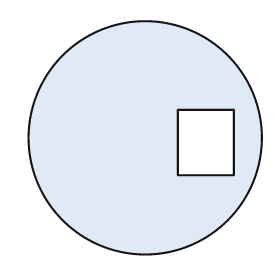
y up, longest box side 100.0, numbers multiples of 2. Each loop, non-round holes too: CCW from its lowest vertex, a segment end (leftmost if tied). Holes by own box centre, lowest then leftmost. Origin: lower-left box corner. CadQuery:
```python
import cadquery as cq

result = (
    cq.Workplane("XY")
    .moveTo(50.0, 50.0)
    .circle(50.0)
    .moveTo(64.0, 34.0)
    .lineTo(88.0, 34.0)
    .lineTo(88.0, 62.0)
    .lineTo(64.0, 62.0)
    .close()
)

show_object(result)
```